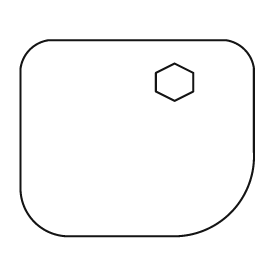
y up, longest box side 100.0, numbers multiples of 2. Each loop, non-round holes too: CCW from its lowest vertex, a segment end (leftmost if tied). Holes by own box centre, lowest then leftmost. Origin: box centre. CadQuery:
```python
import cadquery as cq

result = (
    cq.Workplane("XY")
    .moveTo(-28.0, -42.0)
    .lineTo(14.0, -42.0)
    .threePointArc((40.0, -32.0), (50.0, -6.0))
    .lineTo(50.0, 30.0)
    .threePointArc((46.0, 38.0), (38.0, 42.0))
    .lineTo(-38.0, 42.0)
    .threePointArc((-46.0, 38.0), (-50.0, 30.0))
    .lineTo(-50.0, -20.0)
    .threePointArc((-44.0, -36.0), (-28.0, -42.0))
    .close()
    .moveTo(16.0, 16.0)
    .lineTo(24.0, 20.0)
    .lineTo(24.0, 28.0)
    .lineTo(16.0, 32.0)
    .lineTo(8.0, 28.0)
    .lineTo(8.0, 20.0)
    .close()
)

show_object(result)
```